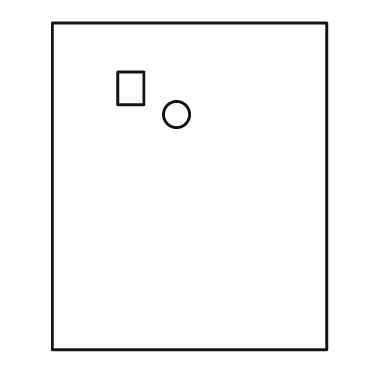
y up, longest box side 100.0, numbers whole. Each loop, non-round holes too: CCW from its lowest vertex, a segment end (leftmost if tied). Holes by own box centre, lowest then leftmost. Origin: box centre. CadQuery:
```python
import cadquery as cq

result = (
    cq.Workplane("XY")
    .moveTo(-42.0, -50.0)
    .lineTo(42.0, -50.0)
    .lineTo(42.0, 50.0)
    .lineTo(-42.0, 50.0)
    .close()
    .moveTo(-4.0, 22.0)
    .circle(4.0)
    .moveTo(-22.0, 25.0)
    .lineTo(-14.0, 25.0)
    .lineTo(-14.0, 35.0)
    .lineTo(-22.0, 35.0)
    .close()
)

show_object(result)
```